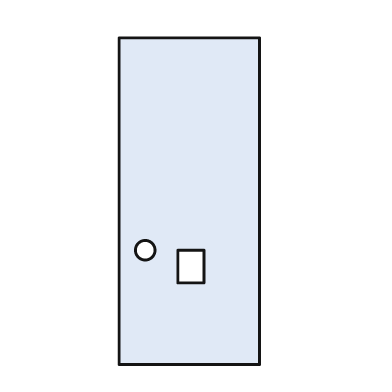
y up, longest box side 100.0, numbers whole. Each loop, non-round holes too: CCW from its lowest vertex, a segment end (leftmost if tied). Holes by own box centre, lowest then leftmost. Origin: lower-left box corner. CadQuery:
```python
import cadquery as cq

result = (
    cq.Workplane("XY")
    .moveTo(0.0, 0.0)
    .lineTo(43.0, 0.0)
    .lineTo(43.0, 100.0)
    .lineTo(0.0, 100.0)
    .close()
    .moveTo(18.0, 25.0)
    .lineTo(26.0, 25.0)
    .lineTo(26.0, 35.0)
    .lineTo(18.0, 35.0)
    .close()
    .moveTo(8.0, 35.0)
    .circle(3.0)
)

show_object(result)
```